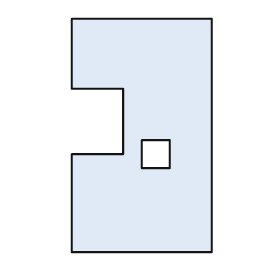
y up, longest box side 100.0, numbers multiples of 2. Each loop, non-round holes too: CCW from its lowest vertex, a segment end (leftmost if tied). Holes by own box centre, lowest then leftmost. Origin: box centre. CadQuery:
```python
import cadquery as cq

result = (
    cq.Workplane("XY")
    .moveTo(-30.0, -50.0)
    .lineTo(30.0, -50.0)
    .lineTo(30.0, 50.0)
    .lineTo(-30.0, 50.0)
    .lineTo(-30.0, 20.0)
    .lineTo(-8.0, 20.0)
    .lineTo(-8.0, -8.0)
    .lineTo(-30.0, -8.0)
    .close()
    .moveTo(0.0, -14.0)
    .lineTo(12.0, -14.0)
    .lineTo(12.0, -2.0)
    .lineTo(0.0, -2.0)
    .close()
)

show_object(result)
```